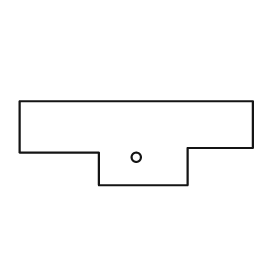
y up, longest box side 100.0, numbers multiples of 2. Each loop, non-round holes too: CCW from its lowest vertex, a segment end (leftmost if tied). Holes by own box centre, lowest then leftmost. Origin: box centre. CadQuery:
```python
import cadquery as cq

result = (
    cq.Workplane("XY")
    .moveTo(-16.0, -18.0)
    .lineTo(22.0, -18.0)
    .lineTo(22.0, -2.0)
    .lineTo(50.0, -2.0)
    .lineTo(50.0, 18.0)
    .lineTo(-50.0, 18.0)
    .lineTo(-50.0, -4.0)
    .lineTo(-16.0, -4.0)
    .close()
    .moveTo(0.0, -6.0)
    .circle(2.0)
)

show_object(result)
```